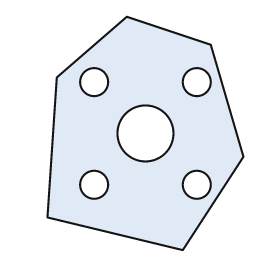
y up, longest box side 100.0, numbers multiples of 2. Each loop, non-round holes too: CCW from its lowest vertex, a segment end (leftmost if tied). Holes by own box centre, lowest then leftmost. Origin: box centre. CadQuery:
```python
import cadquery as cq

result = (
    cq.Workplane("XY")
    .moveTo(16.0, -50.0)
    .lineTo(42.0, -10.0)
    .lineTo(28.0, 38.0)
    .lineTo(-8.0, 50.0)
    .lineTo(-38.0, 24.0)
    .lineTo(-42.0, -36.0)
    .close()
    .moveTo(-22.0, -22.0)
    .circle(6.0)
    .moveTo(22.0, -22.0)
    .circle(6.0)
    .moveTo(0.0, 0.0)
    .circle(12.0)
    .moveTo(-22.0, 22.0)
    .circle(6.0)
    .moveTo(22.0, 22.0)
    .circle(6.0)
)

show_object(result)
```